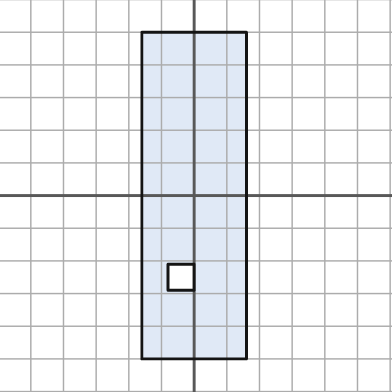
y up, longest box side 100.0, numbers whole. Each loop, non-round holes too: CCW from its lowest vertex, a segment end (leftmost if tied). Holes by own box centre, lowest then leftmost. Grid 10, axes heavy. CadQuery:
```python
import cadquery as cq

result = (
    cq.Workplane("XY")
    .moveTo(-16.0, -50.0)
    .lineTo(16.0, -50.0)
    .lineTo(16.0, 50.0)
    .lineTo(-16.0, 50.0)
    .close()
    .moveTo(-8.0, -29.0)
    .lineTo(0.0, -29.0)
    .lineTo(0.0, -21.0)
    .lineTo(-8.0, -21.0)
    .close()
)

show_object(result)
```